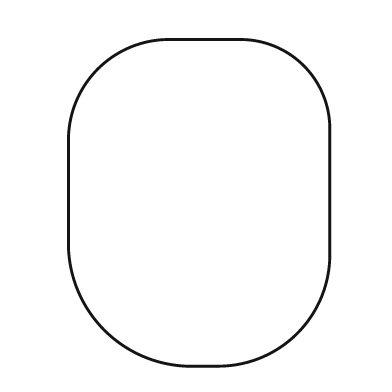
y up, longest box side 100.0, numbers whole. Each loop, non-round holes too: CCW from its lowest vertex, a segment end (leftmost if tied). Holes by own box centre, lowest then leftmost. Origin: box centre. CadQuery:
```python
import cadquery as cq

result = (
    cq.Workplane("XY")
    .moveTo(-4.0, -50.0)
    .lineTo(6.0, -50.0)
    .threePointArc((30.0, -40.0), (40.0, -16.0))
    .lineTo(40.0, 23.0)
    .threePointArc((32.0, 42.0), (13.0, 50.0))
    .lineTo(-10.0, 50.0)
    .threePointArc((-31.0, 41.0), (-40.0, 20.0))
    .lineTo(-40.0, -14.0)
    .threePointArc((-29.0, -39.0), (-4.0, -50.0))
    .close()
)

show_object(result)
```